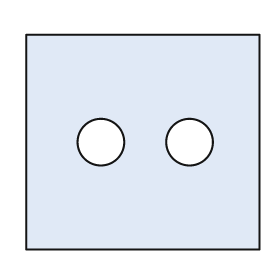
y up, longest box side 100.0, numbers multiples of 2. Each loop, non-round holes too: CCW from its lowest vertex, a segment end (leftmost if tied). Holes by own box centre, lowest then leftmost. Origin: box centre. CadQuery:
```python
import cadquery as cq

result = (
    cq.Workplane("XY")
    .moveTo(-50.0, -46.0)
    .lineTo(50.0, -46.0)
    .lineTo(50.0, 46.0)
    .lineTo(-50.0, 46.0)
    .close()
    .moveTo(-18.0, 0.0)
    .circle(10.0)
    .moveTo(20.0, 0.0)
    .circle(10.0)
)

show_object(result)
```